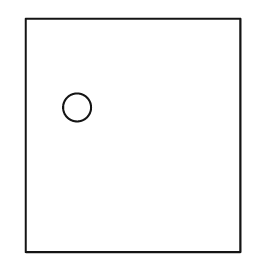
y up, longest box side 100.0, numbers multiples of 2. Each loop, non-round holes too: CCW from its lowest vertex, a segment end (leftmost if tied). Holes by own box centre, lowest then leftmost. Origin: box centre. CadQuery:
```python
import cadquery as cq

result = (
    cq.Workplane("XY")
    .moveTo(-46.0, -50.0)
    .lineTo(46.0, -50.0)
    .lineTo(46.0, 50.0)
    .lineTo(-46.0, 50.0)
    .close()
    .moveTo(-24.0, 12.0)
    .circle(6.0)
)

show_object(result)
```